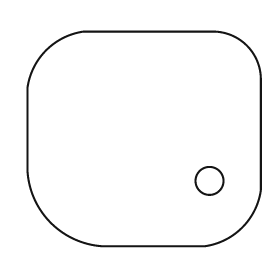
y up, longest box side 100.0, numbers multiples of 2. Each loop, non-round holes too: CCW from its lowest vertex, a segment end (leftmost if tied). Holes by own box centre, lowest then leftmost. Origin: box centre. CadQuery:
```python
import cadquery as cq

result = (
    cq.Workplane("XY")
    .moveTo(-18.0, -46.0)
    .lineTo(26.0, -46.0)
    .threePointArc((42.0, -38.0), (50.0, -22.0))
    .lineTo(50.0, 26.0)
    .threePointArc((44.0, 40.0), (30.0, 46.0))
    .lineTo(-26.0, 46.0)
    .threePointArc((-42.0, 38.0), (-50.0, 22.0))
    .lineTo(-50.0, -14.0)
    .threePointArc((-40.0, -36.0), (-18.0, -46.0))
    .close()
    .moveTo(28.0, -18.0)
    .circle(6.0)
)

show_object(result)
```